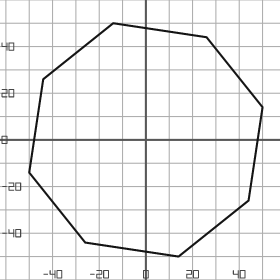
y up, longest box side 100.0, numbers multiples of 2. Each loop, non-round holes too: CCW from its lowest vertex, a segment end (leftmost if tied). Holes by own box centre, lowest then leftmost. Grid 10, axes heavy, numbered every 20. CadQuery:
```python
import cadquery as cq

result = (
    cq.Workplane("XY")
    .moveTo(14.0, -50.0)
    .lineTo(44.0, -26.0)
    .lineTo(50.0, 14.0)
    .lineTo(26.0, 44.0)
    .lineTo(-14.0, 50.0)
    .lineTo(-44.0, 26.0)
    .lineTo(-50.0, -14.0)
    .lineTo(-26.0, -44.0)
    .close()
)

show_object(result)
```